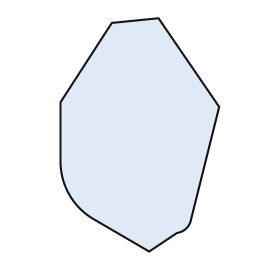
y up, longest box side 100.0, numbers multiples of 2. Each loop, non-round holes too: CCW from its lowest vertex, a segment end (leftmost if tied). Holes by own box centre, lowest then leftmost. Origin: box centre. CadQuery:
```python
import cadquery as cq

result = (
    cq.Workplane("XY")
    .moveTo(4.0, -50.0)
    .lineTo(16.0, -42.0)
    .threePointArc((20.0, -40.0), (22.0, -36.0))
    .lineTo(34.0, 12.0)
    .lineTo(8.0, 50.0)
    .lineTo(-12.0, 48.0)
    .lineTo(-34.0, 14.0)
    .lineTo(-34.0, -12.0)
    .threePointArc((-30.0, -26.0), (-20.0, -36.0))
    .close()
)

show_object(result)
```